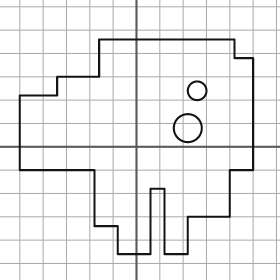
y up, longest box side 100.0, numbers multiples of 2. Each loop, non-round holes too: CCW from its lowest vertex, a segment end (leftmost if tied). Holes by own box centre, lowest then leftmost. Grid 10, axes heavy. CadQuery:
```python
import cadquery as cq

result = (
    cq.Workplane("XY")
    .moveTo(-8.0, -46.0)
    .lineTo(6.0, -46.0)
    .lineTo(6.0, -18.0)
    .lineTo(12.0, -18.0)
    .lineTo(12.0, -46.0)
    .lineTo(22.0, -46.0)
    .lineTo(22.0, -30.0)
    .lineTo(40.0, -30.0)
    .lineTo(40.0, -10.0)
    .lineTo(50.0, -10.0)
    .lineTo(50.0, 38.0)
    .lineTo(42.0, 38.0)
    .lineTo(42.0, 46.0)
    .lineTo(-16.0, 46.0)
    .lineTo(-16.0, 30.0)
    .lineTo(-34.0, 30.0)
    .lineTo(-34.0, 22.0)
    .lineTo(-50.0, 22.0)
    .lineTo(-50.0, -10.0)
    .lineTo(-18.0, -10.0)
    .lineTo(-18.0, -34.0)
    .lineTo(-8.0, -34.0)
    .close()
    .moveTo(22.0, 8.0)
    .circle(6.0)
    .moveTo(26.0, 24.0)
    .circle(4.0)
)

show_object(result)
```